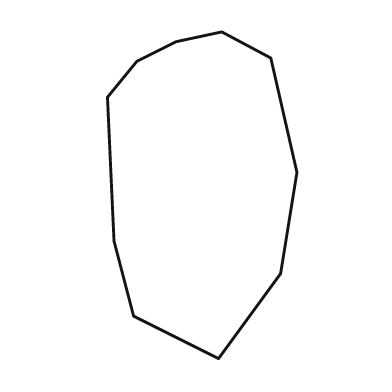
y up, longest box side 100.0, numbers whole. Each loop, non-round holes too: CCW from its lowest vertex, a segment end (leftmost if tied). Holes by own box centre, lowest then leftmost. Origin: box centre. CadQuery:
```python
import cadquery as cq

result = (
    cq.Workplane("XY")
    .moveTo(5.0, -50.0)
    .lineTo(24.0, -24.0)
    .lineTo(29.0, 7.0)
    .lineTo(21.0, 42.0)
    .lineTo(6.0, 50.0)
    .lineTo(-8.0, 47.0)
    .lineTo(-20.0, 41.0)
    .lineTo(-29.0, 30.0)
    .lineTo(-27.0, -14.0)
    .lineTo(-21.0, -37.0)
    .close()
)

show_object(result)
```